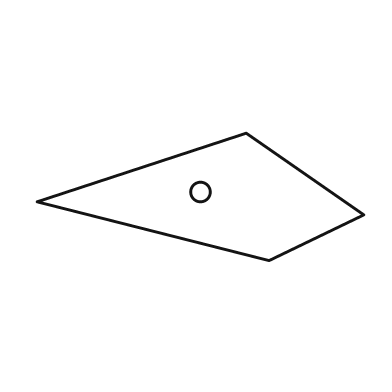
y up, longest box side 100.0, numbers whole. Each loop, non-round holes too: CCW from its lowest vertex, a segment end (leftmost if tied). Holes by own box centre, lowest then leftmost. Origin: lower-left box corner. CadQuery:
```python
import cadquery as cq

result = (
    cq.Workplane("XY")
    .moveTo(71.0, 0.0)
    .lineTo(100.0, 14.0)
    .lineTo(64.0, 39.0)
    .lineTo(0.0, 18.0)
    .close()
    .moveTo(50.0, 21.0)
    .circle(3.0)
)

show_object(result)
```